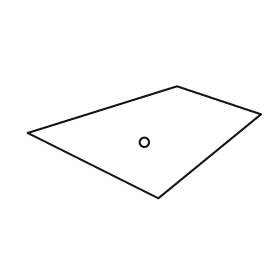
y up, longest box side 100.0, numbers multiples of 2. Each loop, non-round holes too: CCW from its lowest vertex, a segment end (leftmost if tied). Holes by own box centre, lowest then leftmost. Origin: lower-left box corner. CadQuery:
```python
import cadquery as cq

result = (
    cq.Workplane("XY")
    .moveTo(56.0, 0.0)
    .lineTo(100.0, 36.0)
    .lineTo(64.0, 48.0)
    .lineTo(0.0, 28.0)
    .close()
    .moveTo(50.0, 24.0)
    .circle(2.0)
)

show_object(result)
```